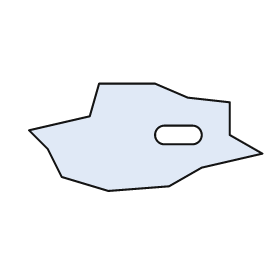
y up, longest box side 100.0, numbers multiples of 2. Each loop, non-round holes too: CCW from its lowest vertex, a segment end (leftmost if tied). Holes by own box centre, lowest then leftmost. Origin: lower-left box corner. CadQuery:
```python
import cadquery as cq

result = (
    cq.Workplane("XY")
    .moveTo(34.0, 0.0)
    .lineTo(60.0, 2.0)
    .lineTo(74.0, 10.0)
    .lineTo(100.0, 16.0)
    .lineTo(86.0, 24.0)
    .lineTo(86.0, 38.0)
    .lineTo(68.0, 40.0)
    .lineTo(54.0, 46.0)
    .lineTo(30.0, 46.0)
    .lineTo(26.0, 32.0)
    .lineTo(0.0, 26.0)
    .lineTo(8.0, 18.0)
    .lineTo(14.0, 6.0)
    .close()
    .moveTo(58.0, 20.0)
    .lineTo(70.0, 20.0)
    .threePointArc((74.0, 24.0), (70.0, 28.0))
    .lineTo(58.0, 28.0)
    .threePointArc((54.0, 24.0), (58.0, 20.0))
    .close()
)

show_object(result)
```